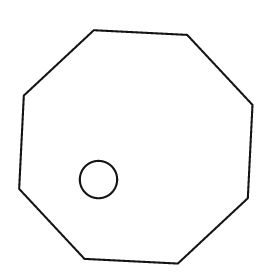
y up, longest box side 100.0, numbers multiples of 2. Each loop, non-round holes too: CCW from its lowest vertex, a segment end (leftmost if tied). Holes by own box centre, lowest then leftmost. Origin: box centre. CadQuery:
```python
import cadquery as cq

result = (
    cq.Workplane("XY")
    .moveTo(18.0, -50.0)
    .lineTo(48.0, -22.0)
    .lineTo(50.0, 18.0)
    .lineTo(22.0, 48.0)
    .lineTo(-18.0, 50.0)
    .lineTo(-48.0, 22.0)
    .lineTo(-50.0, -18.0)
    .lineTo(-22.0, -48.0)
    .close()
    .moveTo(-16.0, -14.0)
    .circle(8.0)
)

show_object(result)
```